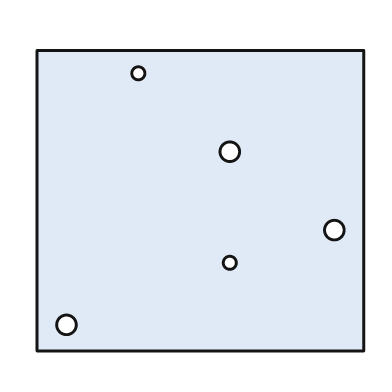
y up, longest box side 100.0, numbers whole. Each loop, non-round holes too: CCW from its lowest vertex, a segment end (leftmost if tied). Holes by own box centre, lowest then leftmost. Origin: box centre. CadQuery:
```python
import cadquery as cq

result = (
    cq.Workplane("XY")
    .moveTo(-50.0, -46.0)
    .lineTo(50.0, -46.0)
    .lineTo(50.0, 46.0)
    .lineTo(-50.0, 46.0)
    .close()
    .moveTo(-41.0, -38.0)
    .circle(3.0)
    .moveTo(9.0, -19.0)
    .circle(2.0)
    .moveTo(41.0, -9.0)
    .circle(3.0)
    .moveTo(9.0, 15.0)
    .circle(3.0)
    .moveTo(-19.0, 39.0)
    .circle(2.0)
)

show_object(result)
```